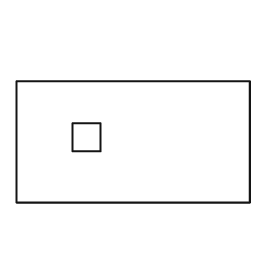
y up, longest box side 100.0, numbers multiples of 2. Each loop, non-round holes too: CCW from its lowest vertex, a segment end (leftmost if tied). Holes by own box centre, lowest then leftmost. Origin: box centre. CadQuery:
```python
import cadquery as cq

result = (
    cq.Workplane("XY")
    .moveTo(-50.0, -26.0)
    .lineTo(50.0, -26.0)
    .lineTo(50.0, 26.0)
    .lineTo(-50.0, 26.0)
    .close()
    .moveTo(-26.0, -4.0)
    .lineTo(-14.0, -4.0)
    .lineTo(-14.0, 8.0)
    .lineTo(-26.0, 8.0)
    .close()
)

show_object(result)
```